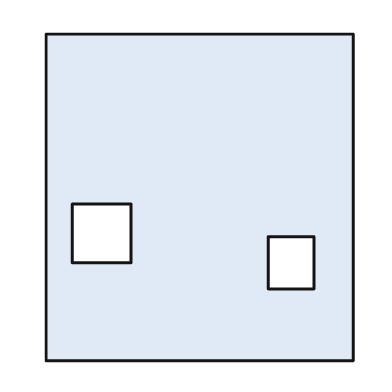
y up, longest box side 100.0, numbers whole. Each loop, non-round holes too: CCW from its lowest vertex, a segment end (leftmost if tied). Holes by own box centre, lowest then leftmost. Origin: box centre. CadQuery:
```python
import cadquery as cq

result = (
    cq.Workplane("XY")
    .moveTo(-47.0, -50.0)
    .lineTo(47.0, -50.0)
    .lineTo(47.0, 50.0)
    .lineTo(-47.0, 50.0)
    .close()
    .moveTo(21.0, -28.0)
    .lineTo(35.0, -28.0)
    .lineTo(35.0, -12.0)
    .lineTo(21.0, -12.0)
    .close()
    .moveTo(-39.0, -20.0)
    .lineTo(-21.0, -20.0)
    .lineTo(-21.0, -2.0)
    .lineTo(-39.0, -2.0)
    .close()
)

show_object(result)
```